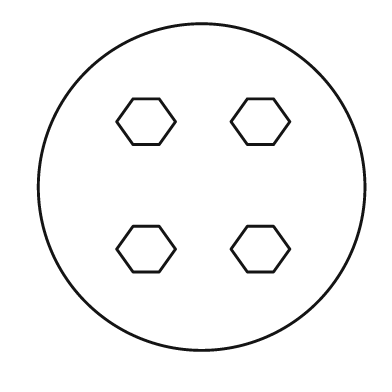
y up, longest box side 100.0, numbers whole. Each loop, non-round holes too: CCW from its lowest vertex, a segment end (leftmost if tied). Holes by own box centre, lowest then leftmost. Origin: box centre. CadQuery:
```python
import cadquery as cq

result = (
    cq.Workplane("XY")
    .moveTo(0.0, 0.0)
    .circle(50.0)
    .moveTo(-21.0, -26.0)
    .lineTo(-13.0, -26.0)
    .lineTo(-8.0, -19.0)
    .lineTo(-13.0, -12.0)
    .lineTo(-21.0, -12.0)
    .lineTo(-26.0, -19.0)
    .close()
    .moveTo(14.0, -26.0)
    .lineTo(22.0, -26.0)
    .lineTo(27.0, -19.0)
    .lineTo(22.0, -12.0)
    .lineTo(14.0, -12.0)
    .lineTo(9.0, -19.0)
    .close()
    .moveTo(-21.0, 13.0)
    .lineTo(-13.0, 13.0)
    .lineTo(-8.0, 20.0)
    .lineTo(-13.0, 27.0)
    .lineTo(-21.0, 27.0)
    .lineTo(-26.0, 20.0)
    .close()
    .moveTo(14.0, 13.0)
    .lineTo(22.0, 13.0)
    .lineTo(27.0, 20.0)
    .lineTo(22.0, 27.0)
    .lineTo(14.0, 27.0)
    .lineTo(9.0, 20.0)
    .close()
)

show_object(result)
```